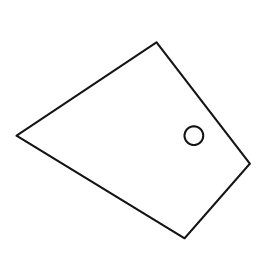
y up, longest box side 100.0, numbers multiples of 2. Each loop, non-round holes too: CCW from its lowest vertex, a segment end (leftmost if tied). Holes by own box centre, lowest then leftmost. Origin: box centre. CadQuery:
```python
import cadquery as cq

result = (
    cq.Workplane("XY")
    .moveTo(22.0, -42.0)
    .lineTo(50.0, -10.0)
    .lineTo(10.0, 42.0)
    .lineTo(-50.0, 2.0)
    .close()
    .moveTo(26.0, 2.0)
    .circle(4.0)
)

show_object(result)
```